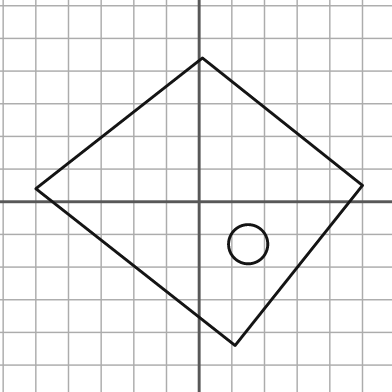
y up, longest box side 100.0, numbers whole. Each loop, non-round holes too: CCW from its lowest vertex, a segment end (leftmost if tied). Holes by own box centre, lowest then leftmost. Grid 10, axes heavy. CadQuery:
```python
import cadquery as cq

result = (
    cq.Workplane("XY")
    .moveTo(11.0, -44.0)
    .lineTo(50.0, 5.0)
    .lineTo(1.0, 44.0)
    .lineTo(-50.0, 4.0)
    .close()
    .moveTo(15.0, -13.0)
    .circle(6.0)
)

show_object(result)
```